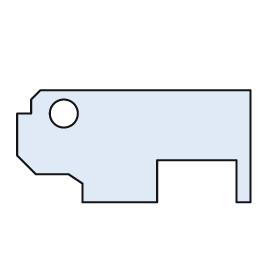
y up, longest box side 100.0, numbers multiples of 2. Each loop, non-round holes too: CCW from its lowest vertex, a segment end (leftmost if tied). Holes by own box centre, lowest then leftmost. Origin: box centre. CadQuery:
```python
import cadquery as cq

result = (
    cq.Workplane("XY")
    .moveTo(-22.0, -24.0)
    .lineTo(10.0, -24.0)
    .lineTo(10.0, -6.0)
    .lineTo(44.0, -6.0)
    .lineTo(44.0, -24.0)
    .lineTo(50.0, -24.0)
    .lineTo(50.0, 24.0)
    .lineTo(-40.0, 24.0)
    .lineTo(-44.0, 20.0)
    .lineTo(-44.0, 14.0)
    .lineTo(-50.0, 14.0)
    .lineTo(-50.0, -4.0)
    .lineTo(-42.0, -12.0)
    .lineTo(-28.0, -12.0)
    .lineTo(-22.0, -16.0)
    .close()
    .moveTo(-30.0, 14.0)
    .circle(6.0)
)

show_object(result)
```